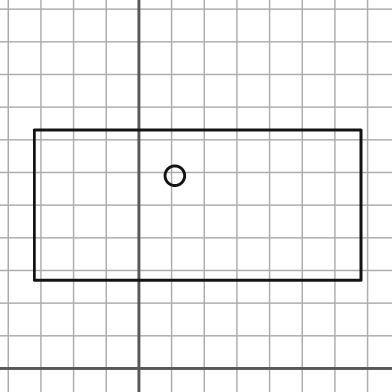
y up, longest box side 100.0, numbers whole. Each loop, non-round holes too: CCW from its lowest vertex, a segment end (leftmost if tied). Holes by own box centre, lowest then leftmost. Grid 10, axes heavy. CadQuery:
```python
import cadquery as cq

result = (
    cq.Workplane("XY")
    .moveTo(-32.0, 27.0)
    .lineTo(68.0, 27.0)
    .lineTo(68.0, 73.0)
    .lineTo(-32.0, 73.0)
    .close()
    .moveTo(11.0, 59.0)
    .circle(3.0)
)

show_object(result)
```